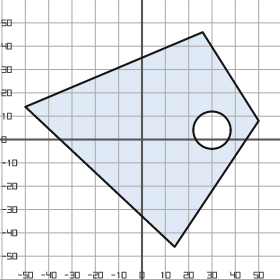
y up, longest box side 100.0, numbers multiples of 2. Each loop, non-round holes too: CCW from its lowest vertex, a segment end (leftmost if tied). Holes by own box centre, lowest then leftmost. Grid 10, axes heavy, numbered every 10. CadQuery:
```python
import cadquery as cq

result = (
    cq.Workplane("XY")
    .moveTo(14.0, -46.0)
    .lineTo(50.0, 8.0)
    .lineTo(26.0, 46.0)
    .lineTo(-50.0, 14.0)
    .close()
    .moveTo(30.0, 4.0)
    .circle(8.0)
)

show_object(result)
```